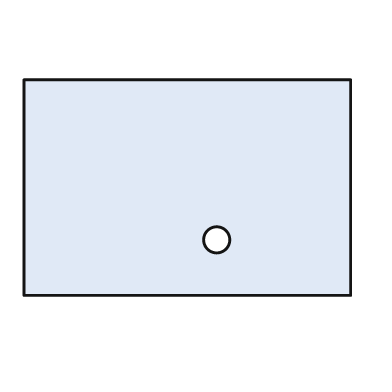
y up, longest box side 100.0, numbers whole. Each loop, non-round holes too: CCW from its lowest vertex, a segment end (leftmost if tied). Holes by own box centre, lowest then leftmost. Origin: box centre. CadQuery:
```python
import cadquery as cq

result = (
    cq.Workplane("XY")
    .moveTo(-50.0, -33.0)
    .lineTo(50.0, -33.0)
    .lineTo(50.0, 33.0)
    .lineTo(-50.0, 33.0)
    .close()
    .moveTo(9.0, -16.0)
    .circle(4.0)
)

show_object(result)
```